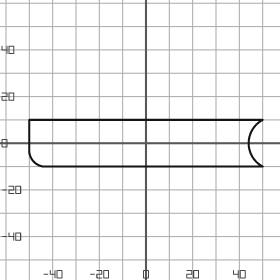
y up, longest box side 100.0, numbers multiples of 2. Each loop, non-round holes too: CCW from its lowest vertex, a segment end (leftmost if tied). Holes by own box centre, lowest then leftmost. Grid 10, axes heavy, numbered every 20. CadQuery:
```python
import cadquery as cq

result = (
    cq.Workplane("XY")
    .moveTo(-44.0, -10.0)
    .lineTo(50.0, -10.0)
    .threePointArc((44.0, 0.0), (50.0, 10.0))
    .lineTo(-50.0, 10.0)
    .lineTo(-50.0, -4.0)
    .threePointArc((-48.0, -8.0), (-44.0, -10.0))
    .close()
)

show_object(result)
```